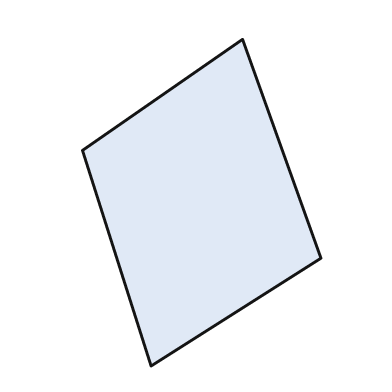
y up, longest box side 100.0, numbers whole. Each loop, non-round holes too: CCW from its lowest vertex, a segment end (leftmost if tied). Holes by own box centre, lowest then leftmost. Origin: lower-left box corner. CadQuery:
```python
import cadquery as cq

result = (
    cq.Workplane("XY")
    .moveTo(21.0, 0.0)
    .lineTo(73.0, 33.0)
    .lineTo(49.0, 100.0)
    .lineTo(0.0, 66.0)
    .close()
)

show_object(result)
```